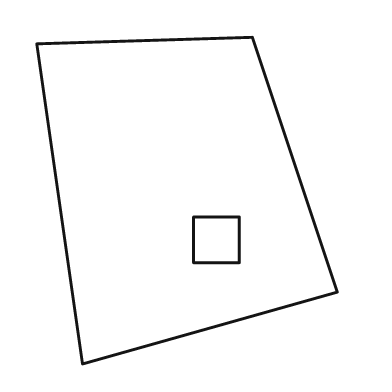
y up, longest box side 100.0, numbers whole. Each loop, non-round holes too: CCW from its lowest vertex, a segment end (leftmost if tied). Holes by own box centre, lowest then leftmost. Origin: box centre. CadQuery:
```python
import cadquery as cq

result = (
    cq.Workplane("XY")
    .moveTo(-32.0, -50.0)
    .lineTo(46.0, -28.0)
    .lineTo(20.0, 50.0)
    .lineTo(-46.0, 48.0)
    .close()
    .moveTo(2.0, -19.0)
    .lineTo(16.0, -19.0)
    .lineTo(16.0, -5.0)
    .lineTo(2.0, -5.0)
    .close()
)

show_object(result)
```